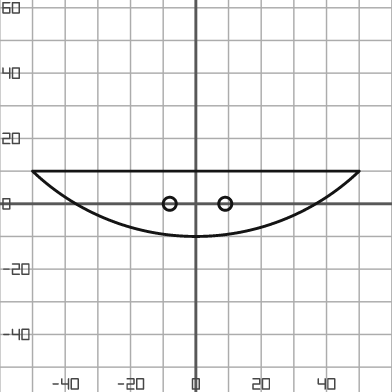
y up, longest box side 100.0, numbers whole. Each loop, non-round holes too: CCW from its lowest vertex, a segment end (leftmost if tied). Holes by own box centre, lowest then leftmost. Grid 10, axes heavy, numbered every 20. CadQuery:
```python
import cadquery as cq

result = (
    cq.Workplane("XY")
    .moveTo(-50.0, 10.0)
    .threePointArc((0.0, -10.0), (50.0, 10.0))
    .close()
    .moveTo(-8.0, 0.0)
    .circle(2.0)
    .moveTo(9.0, 0.0)
    .circle(2.0)
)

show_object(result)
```